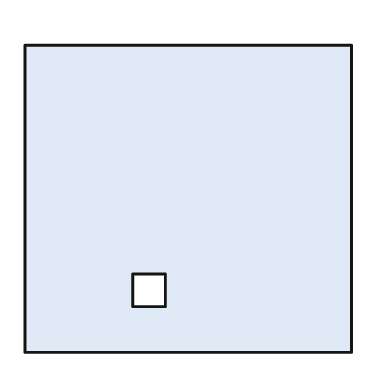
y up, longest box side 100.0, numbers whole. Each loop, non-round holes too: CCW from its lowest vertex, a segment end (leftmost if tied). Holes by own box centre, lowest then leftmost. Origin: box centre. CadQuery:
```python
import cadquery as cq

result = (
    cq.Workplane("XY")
    .moveTo(-50.0, -47.0)
    .lineTo(50.0, -47.0)
    .lineTo(50.0, 47.0)
    .lineTo(-50.0, 47.0)
    .close()
    .moveTo(-17.0, -33.0)
    .lineTo(-7.0, -33.0)
    .lineTo(-7.0, -23.0)
    .lineTo(-17.0, -23.0)
    .close()
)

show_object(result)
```